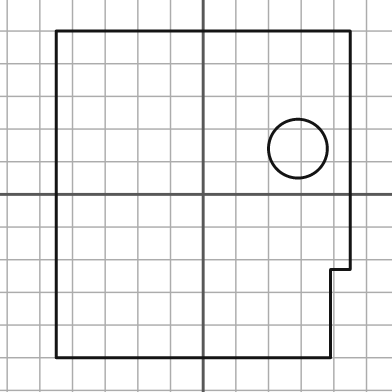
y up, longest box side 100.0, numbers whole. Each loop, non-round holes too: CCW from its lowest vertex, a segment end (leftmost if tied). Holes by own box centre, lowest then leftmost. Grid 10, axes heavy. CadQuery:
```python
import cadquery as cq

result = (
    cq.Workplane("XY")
    .moveTo(-45.0, -50.0)
    .lineTo(39.0, -50.0)
    .lineTo(39.0, -23.0)
    .lineTo(45.0, -23.0)
    .lineTo(45.0, 50.0)
    .lineTo(-45.0, 50.0)
    .close()
    .moveTo(29.0, 14.0)
    .circle(9.0)
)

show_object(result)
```